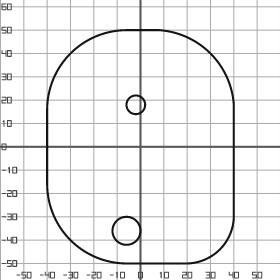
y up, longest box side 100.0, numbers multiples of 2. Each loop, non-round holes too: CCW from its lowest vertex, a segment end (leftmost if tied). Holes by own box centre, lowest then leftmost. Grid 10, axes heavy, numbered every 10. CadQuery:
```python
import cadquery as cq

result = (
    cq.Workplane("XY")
    .moveTo(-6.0, -50.0)
    .lineTo(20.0, -50.0)
    .threePointArc((34.0, -44.0), (40.0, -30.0))
    .lineTo(40.0, 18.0)
    .threePointArc((30.0, 40.0), (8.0, 50.0))
    .lineTo(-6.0, 50.0)
    .threePointArc((-30.0, 40.0), (-40.0, 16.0))
    .lineTo(-40.0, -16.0)
    .threePointArc((-30.0, -40.0), (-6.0, -50.0))
    .close()
    .moveTo(-6.0, -36.0)
    .circle(6.0)
    .moveTo(-2.0, 18.0)
    .circle(4.0)
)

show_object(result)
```